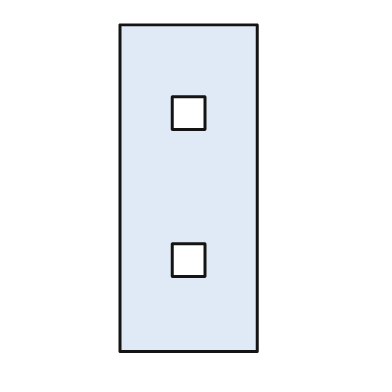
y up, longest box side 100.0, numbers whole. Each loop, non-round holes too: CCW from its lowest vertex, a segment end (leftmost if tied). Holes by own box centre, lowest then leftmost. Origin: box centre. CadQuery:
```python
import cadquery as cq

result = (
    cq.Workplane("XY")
    .moveTo(-21.0, -50.0)
    .lineTo(21.0, -50.0)
    .lineTo(21.0, 50.0)
    .lineTo(-21.0, 50.0)
    .close()
    .moveTo(-5.0, -27.0)
    .lineTo(5.0, -27.0)
    .lineTo(5.0, -17.0)
    .lineTo(-5.0, -17.0)
    .close()
    .moveTo(-5.0, 18.0)
    .lineTo(5.0, 18.0)
    .lineTo(5.0, 28.0)
    .lineTo(-5.0, 28.0)
    .close()
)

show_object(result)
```